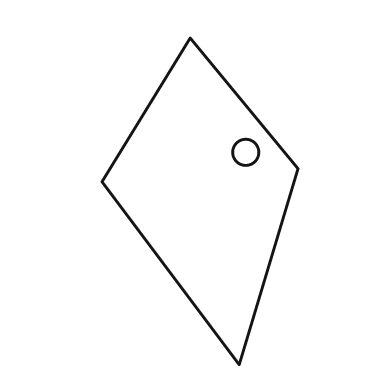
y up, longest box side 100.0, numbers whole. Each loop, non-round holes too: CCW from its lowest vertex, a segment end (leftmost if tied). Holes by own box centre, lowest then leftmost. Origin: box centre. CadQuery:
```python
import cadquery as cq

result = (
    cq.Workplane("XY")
    .moveTo(12.0, -50.0)
    .lineTo(30.0, 10.0)
    .lineTo(-3.0, 50.0)
    .lineTo(-30.0, 6.0)
    .close()
    .moveTo(14.0, 15.0)
    .circle(4.0)
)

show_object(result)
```